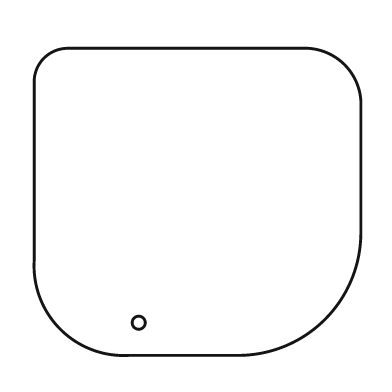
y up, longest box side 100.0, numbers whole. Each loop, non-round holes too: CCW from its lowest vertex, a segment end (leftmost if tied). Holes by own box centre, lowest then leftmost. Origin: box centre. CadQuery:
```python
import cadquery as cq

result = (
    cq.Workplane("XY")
    .moveTo(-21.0, -47.0)
    .lineTo(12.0, -47.0)
    .threePointArc((39.0, -36.0), (50.0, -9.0))
    .lineTo(50.0, 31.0)
    .threePointArc((45.0, 42.0), (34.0, 47.0))
    .lineTo(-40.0, 47.0)
    .threePointArc((-47.0, 44.0), (-50.0, 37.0))
    .lineTo(-50.0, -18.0)
    .threePointArc((-42.0, -39.0), (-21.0, -47.0))
    .close()
    .moveTo(-18.0, -37.0)
    .circle(2.0)
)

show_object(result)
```